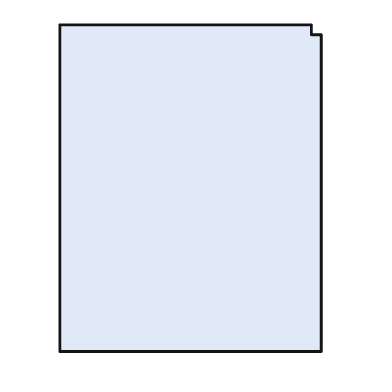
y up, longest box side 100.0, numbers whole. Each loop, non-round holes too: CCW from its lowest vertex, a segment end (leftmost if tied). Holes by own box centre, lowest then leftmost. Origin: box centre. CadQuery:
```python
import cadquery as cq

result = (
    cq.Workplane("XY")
    .moveTo(-40.0, -50.0)
    .lineTo(40.0, -50.0)
    .lineTo(40.0, 47.0)
    .lineTo(37.0, 47.0)
    .lineTo(37.0, 50.0)
    .lineTo(-40.0, 50.0)
    .close()
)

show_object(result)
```